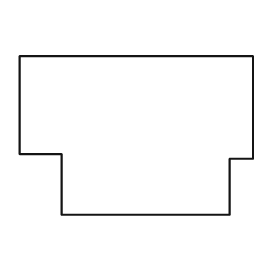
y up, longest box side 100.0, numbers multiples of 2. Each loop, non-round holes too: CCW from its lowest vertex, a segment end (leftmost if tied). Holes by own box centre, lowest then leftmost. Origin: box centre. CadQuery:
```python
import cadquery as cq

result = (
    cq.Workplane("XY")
    .moveTo(-32.0, -34.0)
    .lineTo(40.0, -34.0)
    .lineTo(40.0, -10.0)
    .lineTo(50.0, -10.0)
    .lineTo(50.0, 34.0)
    .lineTo(-50.0, 34.0)
    .lineTo(-50.0, -8.0)
    .lineTo(-32.0, -8.0)
    .close()
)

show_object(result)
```